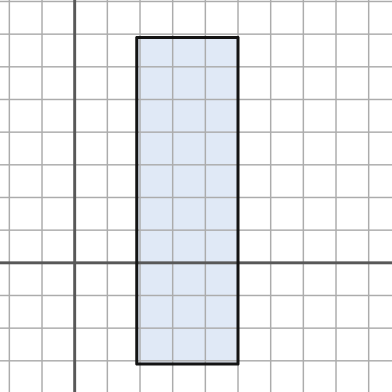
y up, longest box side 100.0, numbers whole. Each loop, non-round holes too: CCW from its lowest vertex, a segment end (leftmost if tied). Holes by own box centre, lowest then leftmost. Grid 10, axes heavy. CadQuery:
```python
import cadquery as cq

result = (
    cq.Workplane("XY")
    .moveTo(19.0, -31.0)
    .lineTo(50.0, -31.0)
    .lineTo(50.0, 69.0)
    .lineTo(19.0, 69.0)
    .close()
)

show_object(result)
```